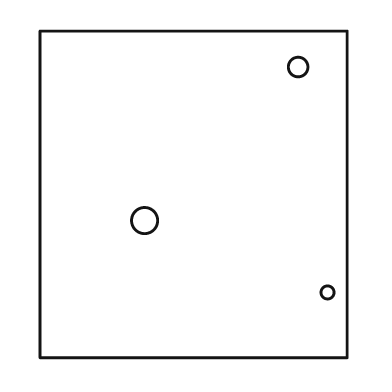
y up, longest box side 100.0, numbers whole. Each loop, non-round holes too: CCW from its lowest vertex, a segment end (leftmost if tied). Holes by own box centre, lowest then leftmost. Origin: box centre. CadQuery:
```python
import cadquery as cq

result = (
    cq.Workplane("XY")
    .moveTo(-47.0, -50.0)
    .lineTo(47.0, -50.0)
    .lineTo(47.0, 50.0)
    .lineTo(-47.0, 50.0)
    .close()
    .moveTo(41.0, -30.0)
    .circle(2.0)
    .moveTo(-15.0, -8.0)
    .circle(4.0)
    .moveTo(32.0, 39.0)
    .circle(3.0)
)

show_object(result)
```